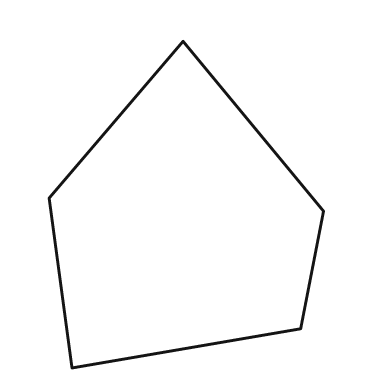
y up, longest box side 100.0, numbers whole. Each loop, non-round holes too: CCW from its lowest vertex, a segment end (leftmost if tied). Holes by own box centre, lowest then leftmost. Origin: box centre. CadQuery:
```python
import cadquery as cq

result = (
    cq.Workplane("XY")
    .moveTo(-35.0, -50.0)
    .lineTo(35.0, -38.0)
    .lineTo(42.0, -2.0)
    .lineTo(-1.0, 50.0)
    .lineTo(-42.0, 2.0)
    .close()
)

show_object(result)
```